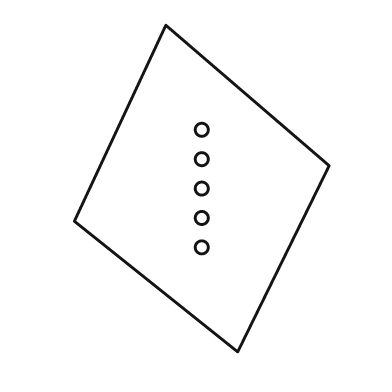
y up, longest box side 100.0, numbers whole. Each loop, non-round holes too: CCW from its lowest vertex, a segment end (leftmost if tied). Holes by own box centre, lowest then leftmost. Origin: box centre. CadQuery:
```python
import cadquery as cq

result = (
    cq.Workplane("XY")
    .moveTo(11.0, -50.0)
    .lineTo(39.0, 7.0)
    .lineTo(-11.0, 50.0)
    .lineTo(-39.0, -10.0)
    .close()
    .moveTo(0.0, -18.0)
    .circle(2.0)
    .moveTo(0.0, -9.0)
    .circle(2.0)
    .moveTo(0.0, 0.0)
    .circle(2.0)
    .moveTo(0.0, 9.0)
    .circle(2.0)
    .moveTo(0.0, 18.0)
    .circle(2.0)
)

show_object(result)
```